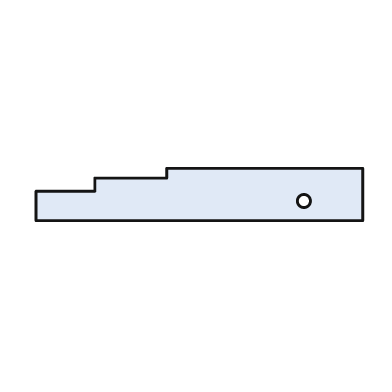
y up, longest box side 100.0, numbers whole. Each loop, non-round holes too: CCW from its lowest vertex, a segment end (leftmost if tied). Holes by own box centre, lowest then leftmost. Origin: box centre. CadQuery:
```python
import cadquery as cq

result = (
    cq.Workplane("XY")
    .moveTo(-50.0, -8.0)
    .lineTo(50.0, -8.0)
    .lineTo(50.0, 8.0)
    .lineTo(-10.0, 8.0)
    .lineTo(-10.0, 5.0)
    .lineTo(-32.0, 5.0)
    .lineTo(-32.0, 1.0)
    .lineTo(-50.0, 1.0)
    .close()
    .moveTo(32.0, -2.0)
    .circle(2.0)
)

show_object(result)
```